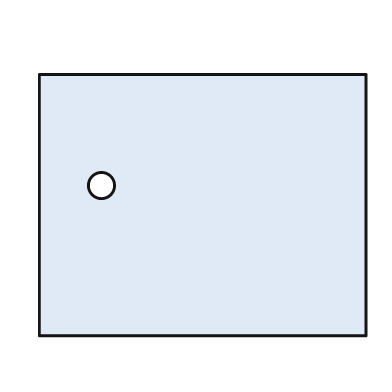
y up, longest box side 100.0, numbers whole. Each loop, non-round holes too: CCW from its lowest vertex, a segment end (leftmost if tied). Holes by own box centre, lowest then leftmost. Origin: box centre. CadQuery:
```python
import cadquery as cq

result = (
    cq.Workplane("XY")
    .moveTo(-50.0, -40.0)
    .lineTo(50.0, -40.0)
    .lineTo(50.0, 40.0)
    .lineTo(-50.0, 40.0)
    .close()
    .moveTo(-31.0, 6.0)
    .circle(4.0)
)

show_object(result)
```